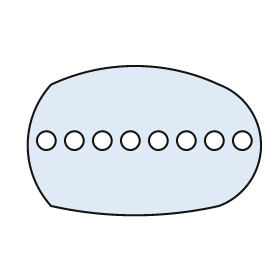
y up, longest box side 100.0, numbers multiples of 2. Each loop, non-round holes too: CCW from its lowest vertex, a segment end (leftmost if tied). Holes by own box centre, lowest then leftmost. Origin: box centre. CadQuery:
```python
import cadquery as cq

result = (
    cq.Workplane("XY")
    .moveTo(-40.0, -28.0)
    .threePointArc((-4.0, -32.0), (32.0, -28.0))
    .threePointArc((50.0, -2.0), (32.0, 24.0))
    .threePointArc((-4.0, 32.0), (-40.0, 24.0))
    .threePointArc((-50.0, -2.0), (-40.0, -28.0))
    .close()
    .moveTo(-42.0, 0.0)
    .circle(4.0)
    .moveTo(-30.0, 0.0)
    .circle(4.0)
    .moveTo(-18.0, 0.0)
    .circle(4.0)
    .moveTo(-6.0, 0.0)
    .circle(4.0)
    .moveTo(6.0, 0.0)
    .circle(4.0)
    .moveTo(18.0, 0.0)
    .circle(4.0)
    .moveTo(30.0, 0.0)
    .circle(4.0)
    .moveTo(42.0, 0.0)
    .circle(4.0)
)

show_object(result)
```